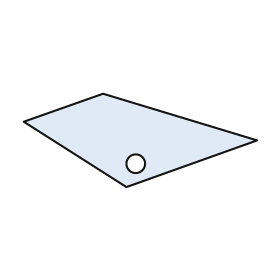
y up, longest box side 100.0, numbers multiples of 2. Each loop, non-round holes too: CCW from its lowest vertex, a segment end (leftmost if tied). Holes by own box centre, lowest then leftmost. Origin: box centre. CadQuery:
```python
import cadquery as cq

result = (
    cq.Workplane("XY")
    .moveTo(-6.0, -20.0)
    .lineTo(50.0, 0.0)
    .lineTo(-16.0, 20.0)
    .lineTo(-50.0, 8.0)
    .close()
    .moveTo(-2.0, -10.0)
    .circle(4.0)
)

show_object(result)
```